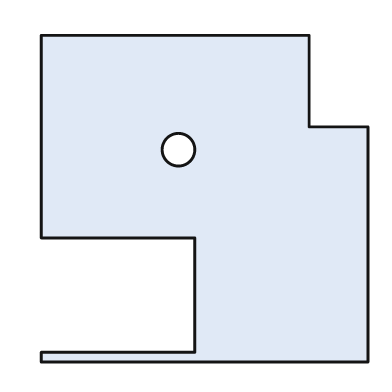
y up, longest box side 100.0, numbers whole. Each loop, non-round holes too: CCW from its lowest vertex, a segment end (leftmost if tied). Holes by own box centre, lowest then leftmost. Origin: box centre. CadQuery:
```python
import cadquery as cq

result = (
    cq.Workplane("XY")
    .moveTo(-50.0, -50.0)
    .lineTo(50.0, -50.0)
    .lineTo(50.0, 22.0)
    .lineTo(32.0, 22.0)
    .lineTo(32.0, 50.0)
    .lineTo(-50.0, 50.0)
    .lineTo(-50.0, -12.0)
    .lineTo(-3.0, -12.0)
    .lineTo(-3.0, -47.0)
    .lineTo(-50.0, -47.0)
    .close()
    .moveTo(-8.0, 15.0)
    .circle(5.0)
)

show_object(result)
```